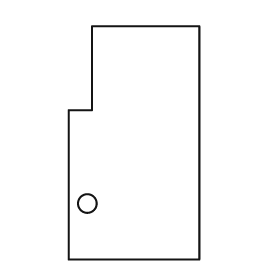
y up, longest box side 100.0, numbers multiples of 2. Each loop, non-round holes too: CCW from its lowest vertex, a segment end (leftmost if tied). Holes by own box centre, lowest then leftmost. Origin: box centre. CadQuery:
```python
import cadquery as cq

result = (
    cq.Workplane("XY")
    .moveTo(-28.0, -50.0)
    .lineTo(28.0, -50.0)
    .lineTo(28.0, 50.0)
    .lineTo(-18.0, 50.0)
    .lineTo(-18.0, 14.0)
    .lineTo(-28.0, 14.0)
    .close()
    .moveTo(-20.0, -26.0)
    .circle(4.0)
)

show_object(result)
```